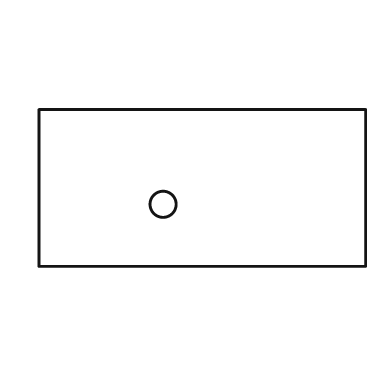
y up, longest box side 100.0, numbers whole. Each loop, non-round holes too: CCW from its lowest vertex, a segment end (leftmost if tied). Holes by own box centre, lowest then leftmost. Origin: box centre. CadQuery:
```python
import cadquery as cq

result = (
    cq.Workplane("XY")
    .moveTo(-50.0, -24.0)
    .lineTo(50.0, -24.0)
    .lineTo(50.0, 24.0)
    .lineTo(-50.0, 24.0)
    .close()
    .moveTo(-12.0, -5.0)
    .circle(4.0)
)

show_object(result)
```